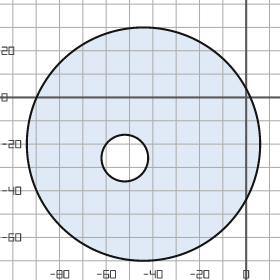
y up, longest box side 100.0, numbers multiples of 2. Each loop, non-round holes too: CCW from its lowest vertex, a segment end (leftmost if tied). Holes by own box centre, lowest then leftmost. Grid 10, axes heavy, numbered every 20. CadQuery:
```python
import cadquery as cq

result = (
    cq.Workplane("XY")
    .moveTo(-44.0, -20.0)
    .circle(50.0)
    .moveTo(-52.0, -26.0)
    .circle(10.0)
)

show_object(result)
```